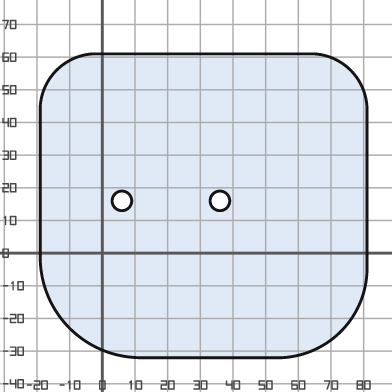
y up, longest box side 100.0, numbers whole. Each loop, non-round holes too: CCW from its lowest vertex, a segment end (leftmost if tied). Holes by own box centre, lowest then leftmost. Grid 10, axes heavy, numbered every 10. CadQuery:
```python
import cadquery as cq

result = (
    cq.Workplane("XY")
    .moveTo(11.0, -32.0)
    .lineTo(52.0, -32.0)
    .threePointArc((73.0, -24.0), (81.0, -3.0))
    .lineTo(81.0, 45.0)
    .threePointArc((76.0, 56.0), (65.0, 61.0))
    .lineTo(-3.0, 61.0)
    .threePointArc((-14.0, 56.0), (-19.0, 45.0))
    .lineTo(-19.0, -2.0)
    .threePointArc((-10.0, -23.0), (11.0, -32.0))
    .close()
    .moveTo(6.0, 16.0)
    .circle(3.0)
    .moveTo(36.0, 16.0)
    .circle(3.0)
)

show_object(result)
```